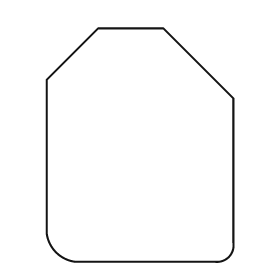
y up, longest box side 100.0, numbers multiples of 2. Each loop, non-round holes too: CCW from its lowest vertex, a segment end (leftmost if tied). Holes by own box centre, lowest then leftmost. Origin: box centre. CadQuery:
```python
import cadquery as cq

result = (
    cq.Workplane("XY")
    .moveTo(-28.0, -50.0)
    .lineTo(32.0, -50.0)
    .threePointArc((38.0, -48.0), (40.0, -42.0))
    .lineTo(40.0, 20.0)
    .lineTo(10.0, 50.0)
    .lineTo(-18.0, 50.0)
    .lineTo(-40.0, 28.0)
    .lineTo(-40.0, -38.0)
    .threePointArc((-36.0, -46.0), (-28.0, -50.0))
    .close()
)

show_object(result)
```